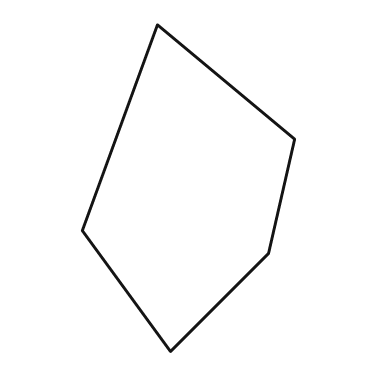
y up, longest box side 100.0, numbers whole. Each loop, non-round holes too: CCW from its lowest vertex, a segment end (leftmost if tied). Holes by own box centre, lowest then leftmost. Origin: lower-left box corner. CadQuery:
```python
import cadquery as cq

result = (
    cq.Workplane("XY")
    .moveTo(27.0, 0.0)
    .lineTo(57.0, 30.0)
    .lineTo(65.0, 65.0)
    .lineTo(23.0, 100.0)
    .lineTo(0.0, 37.0)
    .close()
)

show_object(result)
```